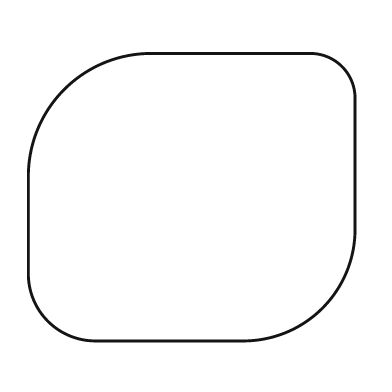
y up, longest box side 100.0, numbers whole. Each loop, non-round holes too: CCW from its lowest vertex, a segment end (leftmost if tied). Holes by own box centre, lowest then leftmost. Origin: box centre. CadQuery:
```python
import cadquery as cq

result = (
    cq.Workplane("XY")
    .moveTo(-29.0, -44.0)
    .lineTo(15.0, -44.0)
    .threePointArc((40.0, -34.0), (50.0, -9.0))
    .lineTo(50.0, 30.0)
    .threePointArc((46.0, 40.0), (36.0, 44.0))
    .lineTo(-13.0, 44.0)
    .threePointArc((-39.0, 33.0), (-50.0, 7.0))
    .lineTo(-50.0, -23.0)
    .threePointArc((-44.0, -38.0), (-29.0, -44.0))
    .close()
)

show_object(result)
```